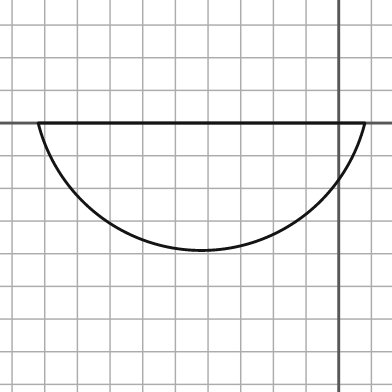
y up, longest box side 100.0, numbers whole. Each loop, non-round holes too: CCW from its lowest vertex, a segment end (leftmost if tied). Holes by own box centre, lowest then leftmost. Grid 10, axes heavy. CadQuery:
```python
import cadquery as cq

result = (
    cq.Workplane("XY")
    .moveTo(-92.0, 0.0)
    .threePointArc((-42.0, -39.0), (8.0, 0.0))
    .close()
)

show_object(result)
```